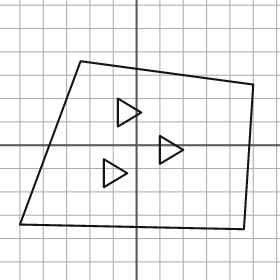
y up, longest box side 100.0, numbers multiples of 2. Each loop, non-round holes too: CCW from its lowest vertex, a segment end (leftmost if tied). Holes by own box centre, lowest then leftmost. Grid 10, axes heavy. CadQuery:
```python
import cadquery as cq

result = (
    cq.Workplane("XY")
    .moveTo(46.0, -36.0)
    .lineTo(50.0, 26.0)
    .lineTo(-24.0, 36.0)
    .lineTo(-50.0, -34.0)
    .close()
    .moveTo(-14.0, -18.0)
    .lineTo(-4.0, -12.0)
    .lineTo(-14.0, -6.0)
    .close()
    .moveTo(10.0, -8.0)
    .lineTo(20.0, -2.0)
    .lineTo(10.0, 4.0)
    .close()
    .moveTo(-8.0, 8.0)
    .lineTo(2.0, 14.0)
    .lineTo(-8.0, 20.0)
    .close()
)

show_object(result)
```